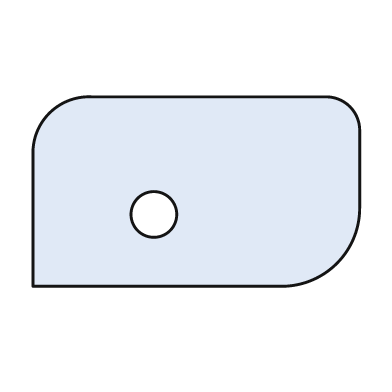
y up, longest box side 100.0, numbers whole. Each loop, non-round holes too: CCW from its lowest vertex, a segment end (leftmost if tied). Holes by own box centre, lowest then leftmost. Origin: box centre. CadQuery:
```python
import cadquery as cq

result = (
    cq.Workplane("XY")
    .moveTo(-50.0, -29.0)
    .lineTo(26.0, -29.0)
    .threePointArc((43.0, -22.0), (50.0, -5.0))
    .lineTo(50.0, 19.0)
    .threePointArc((47.0, 26.0), (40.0, 29.0))
    .lineTo(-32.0, 29.0)
    .threePointArc((-45.0, 24.0), (-50.0, 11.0))
    .close()
    .moveTo(-13.0, -7.0)
    .circle(7.0)
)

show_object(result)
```